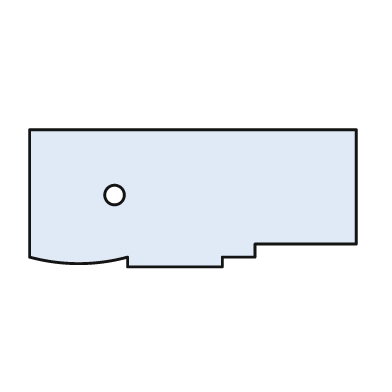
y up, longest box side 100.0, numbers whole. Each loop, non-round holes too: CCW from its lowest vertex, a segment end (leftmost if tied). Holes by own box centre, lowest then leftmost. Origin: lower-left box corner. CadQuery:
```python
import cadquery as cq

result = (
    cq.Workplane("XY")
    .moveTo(30.0, 0.0)
    .lineTo(59.0, 0.0)
    .lineTo(59.0, 3.0)
    .lineTo(69.0, 3.0)
    .lineTo(69.0, 7.0)
    .lineTo(100.0, 7.0)
    .lineTo(100.0, 42.0)
    .lineTo(0.0, 42.0)
    .lineTo(0.0, 3.0)
    .threePointArc((15.0, 1.0), (30.0, 3.0))
    .close()
    .moveTo(26.0, 22.0)
    .circle(3.0)
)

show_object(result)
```